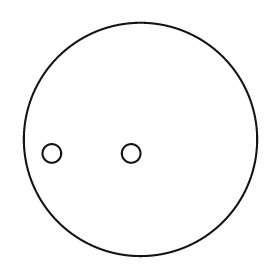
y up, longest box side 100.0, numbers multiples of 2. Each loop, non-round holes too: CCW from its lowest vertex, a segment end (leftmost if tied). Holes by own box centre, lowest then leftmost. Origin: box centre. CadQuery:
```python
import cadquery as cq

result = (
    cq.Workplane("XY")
    .moveTo(0.0, 0.0)
    .circle(50.0)
    .moveTo(-38.0, -6.0)
    .circle(4.0)
    .moveTo(-4.0, -6.0)
    .circle(4.0)
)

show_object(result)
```